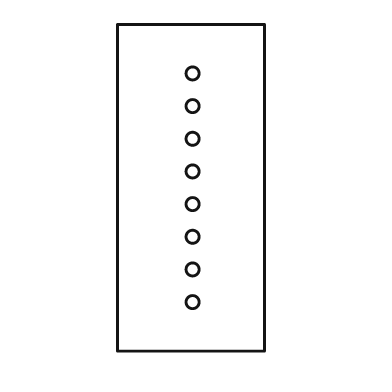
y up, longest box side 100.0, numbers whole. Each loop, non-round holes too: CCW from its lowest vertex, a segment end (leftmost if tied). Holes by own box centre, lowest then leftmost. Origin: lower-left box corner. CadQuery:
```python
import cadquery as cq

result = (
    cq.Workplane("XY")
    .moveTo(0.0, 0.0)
    .lineTo(45.0, 0.0)
    .lineTo(45.0, 100.0)
    .lineTo(0.0, 100.0)
    .close()
    .moveTo(23.0, 15.0)
    .circle(2.0)
    .moveTo(23.0, 25.0)
    .circle(2.0)
    .moveTo(23.0, 35.0)
    .circle(2.0)
    .moveTo(23.0, 45.0)
    .circle(2.0)
    .moveTo(23.0, 55.0)
    .circle(2.0)
    .moveTo(23.0, 65.0)
    .circle(2.0)
    .moveTo(23.0, 75.0)
    .circle(2.0)
    .moveTo(23.0, 85.0)
    .circle(2.0)
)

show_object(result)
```